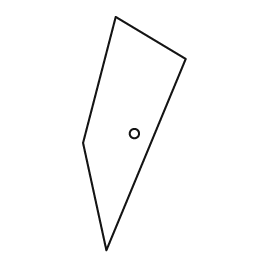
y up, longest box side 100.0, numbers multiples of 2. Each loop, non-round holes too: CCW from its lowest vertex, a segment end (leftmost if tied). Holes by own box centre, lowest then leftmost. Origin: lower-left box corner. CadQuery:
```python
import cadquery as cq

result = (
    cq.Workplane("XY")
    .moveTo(10.0, 0.0)
    .lineTo(44.0, 82.0)
    .lineTo(14.0, 100.0)
    .lineTo(0.0, 46.0)
    .close()
    .moveTo(22.0, 50.0)
    .circle(2.0)
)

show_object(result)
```